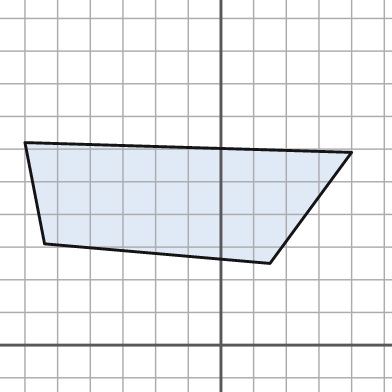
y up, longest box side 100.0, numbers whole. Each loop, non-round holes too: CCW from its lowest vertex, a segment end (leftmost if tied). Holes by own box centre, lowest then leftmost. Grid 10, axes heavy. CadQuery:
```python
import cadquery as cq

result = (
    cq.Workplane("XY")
    .moveTo(15.0, 25.0)
    .lineTo(40.0, 59.0)
    .lineTo(-60.0, 62.0)
    .lineTo(-54.0, 31.0)
    .close()
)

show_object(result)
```